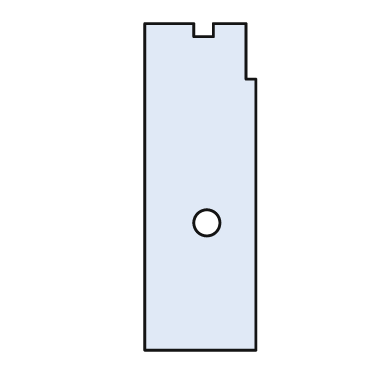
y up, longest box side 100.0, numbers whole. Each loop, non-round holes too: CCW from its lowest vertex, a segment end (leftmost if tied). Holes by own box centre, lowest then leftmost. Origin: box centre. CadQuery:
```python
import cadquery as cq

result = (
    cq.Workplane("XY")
    .moveTo(-17.0, -50.0)
    .lineTo(17.0, -50.0)
    .lineTo(17.0, 33.0)
    .lineTo(14.0, 33.0)
    .lineTo(14.0, 50.0)
    .lineTo(4.0, 50.0)
    .lineTo(4.0, 46.0)
    .lineTo(-2.0, 46.0)
    .lineTo(-2.0, 50.0)
    .lineTo(-17.0, 50.0)
    .close()
    .moveTo(2.0, -11.0)
    .circle(4.0)
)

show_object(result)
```